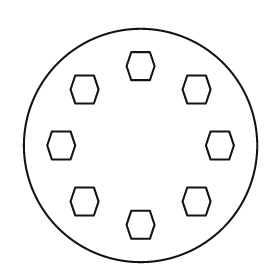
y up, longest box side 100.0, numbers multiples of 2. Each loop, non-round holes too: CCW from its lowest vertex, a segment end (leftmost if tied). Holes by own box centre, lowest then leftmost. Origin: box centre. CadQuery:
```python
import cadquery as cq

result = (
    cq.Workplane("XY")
    .moveTo(0.0, 0.0)
    .circle(50.0)
    .moveTo(-4.0, -40.0)
    .lineTo(4.0, -40.0)
    .lineTo(6.0, -34.0)
    .lineTo(4.0, -28.0)
    .lineTo(-4.0, -28.0)
    .lineTo(-6.0, -34.0)
    .close()
    .moveTo(-28.0, -30.0)
    .lineTo(-20.0, -30.0)
    .lineTo(-18.0, -24.0)
    .lineTo(-20.0, -18.0)
    .lineTo(-28.0, -18.0)
    .lineTo(-30.0, -24.0)
    .close()
    .moveTo(20.0, -30.0)
    .lineTo(28.0, -30.0)
    .lineTo(30.0, -24.0)
    .lineTo(28.0, -18.0)
    .lineTo(20.0, -18.0)
    .lineTo(18.0, -24.0)
    .close()
    .moveTo(-38.0, -6.0)
    .lineTo(-30.0, -6.0)
    .lineTo(-28.0, 0.0)
    .lineTo(-30.0, 6.0)
    .lineTo(-38.0, 6.0)
    .lineTo(-40.0, 0.0)
    .close()
    .moveTo(30.0, -6.0)
    .lineTo(38.0, -6.0)
    .lineTo(40.0, 0.0)
    .lineTo(38.0, 6.0)
    .lineTo(30.0, 6.0)
    .lineTo(28.0, 0.0)
    .close()
    .moveTo(-28.0, 18.0)
    .lineTo(-20.0, 18.0)
    .lineTo(-18.0, 24.0)
    .lineTo(-20.0, 30.0)
    .lineTo(-28.0, 30.0)
    .lineTo(-30.0, 24.0)
    .close()
    .moveTo(20.0, 18.0)
    .lineTo(28.0, 18.0)
    .lineTo(30.0, 24.0)
    .lineTo(28.0, 30.0)
    .lineTo(20.0, 30.0)
    .lineTo(18.0, 24.0)
    .close()
    .moveTo(-4.0, 28.0)
    .lineTo(4.0, 28.0)
    .lineTo(6.0, 34.0)
    .lineTo(4.0, 40.0)
    .lineTo(-4.0, 40.0)
    .lineTo(-6.0, 34.0)
    .close()
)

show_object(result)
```